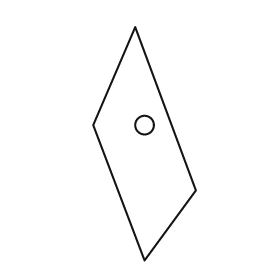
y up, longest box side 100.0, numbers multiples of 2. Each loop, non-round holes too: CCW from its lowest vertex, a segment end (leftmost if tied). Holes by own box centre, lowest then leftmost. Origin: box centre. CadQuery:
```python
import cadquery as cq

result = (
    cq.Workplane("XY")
    .moveTo(0.0, -50.0)
    .lineTo(22.0, -20.0)
    .lineTo(-4.0, 50.0)
    .lineTo(-22.0, 8.0)
    .close()
    .moveTo(0.0, 8.0)
    .circle(4.0)
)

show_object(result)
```